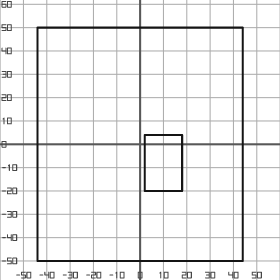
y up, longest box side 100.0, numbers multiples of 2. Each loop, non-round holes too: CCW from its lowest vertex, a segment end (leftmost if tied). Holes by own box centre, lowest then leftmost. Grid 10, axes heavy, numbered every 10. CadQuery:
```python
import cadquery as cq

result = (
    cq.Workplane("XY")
    .moveTo(-44.0, -50.0)
    .lineTo(44.0, -50.0)
    .lineTo(44.0, 50.0)
    .lineTo(-44.0, 50.0)
    .close()
    .moveTo(2.0, -20.0)
    .lineTo(18.0, -20.0)
    .lineTo(18.0, 4.0)
    .lineTo(2.0, 4.0)
    .close()
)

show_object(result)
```